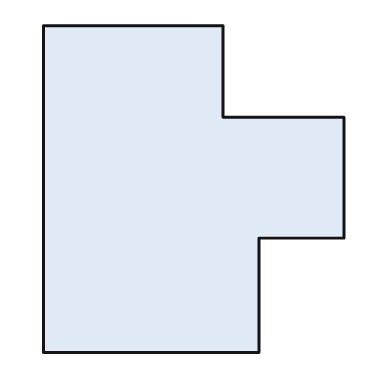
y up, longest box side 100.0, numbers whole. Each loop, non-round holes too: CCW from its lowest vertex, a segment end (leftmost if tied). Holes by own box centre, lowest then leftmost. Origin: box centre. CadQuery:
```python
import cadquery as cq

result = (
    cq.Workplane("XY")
    .moveTo(-46.0, -50.0)
    .lineTo(20.0, -50.0)
    .lineTo(20.0, -15.0)
    .lineTo(46.0, -15.0)
    .lineTo(46.0, 22.0)
    .lineTo(9.0, 22.0)
    .lineTo(9.0, 50.0)
    .lineTo(-46.0, 50.0)
    .close()
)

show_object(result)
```